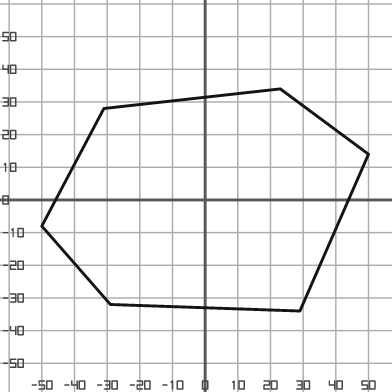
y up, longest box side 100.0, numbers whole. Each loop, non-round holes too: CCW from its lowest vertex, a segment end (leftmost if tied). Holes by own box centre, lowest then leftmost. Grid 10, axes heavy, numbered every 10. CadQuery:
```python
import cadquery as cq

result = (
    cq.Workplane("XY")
    .moveTo(29.0, -34.0)
    .lineTo(50.0, 14.0)
    .lineTo(23.0, 34.0)
    .lineTo(-31.0, 28.0)
    .lineTo(-50.0, -8.0)
    .lineTo(-29.0, -32.0)
    .close()
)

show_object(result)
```